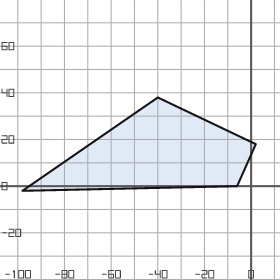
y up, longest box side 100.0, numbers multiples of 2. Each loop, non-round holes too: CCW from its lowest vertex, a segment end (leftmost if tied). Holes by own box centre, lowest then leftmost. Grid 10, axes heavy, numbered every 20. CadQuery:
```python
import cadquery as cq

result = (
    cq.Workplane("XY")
    .moveTo(-98.0, -2.0)
    .lineTo(-6.0, 0.0)
    .lineTo(2.0, 18.0)
    .lineTo(-40.0, 38.0)
    .close()
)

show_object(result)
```